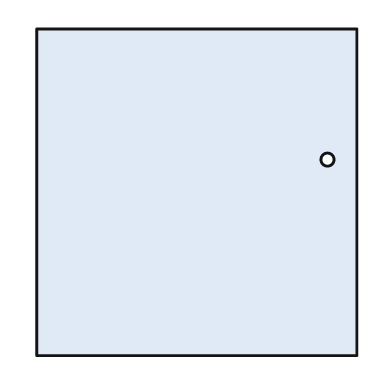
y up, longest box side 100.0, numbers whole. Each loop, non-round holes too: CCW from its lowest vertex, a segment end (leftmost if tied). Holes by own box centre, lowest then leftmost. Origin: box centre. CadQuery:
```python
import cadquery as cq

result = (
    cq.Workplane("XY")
    .moveTo(-49.0, -50.0)
    .lineTo(49.0, -50.0)
    .lineTo(49.0, 50.0)
    .lineTo(-49.0, 50.0)
    .close()
    .moveTo(40.0, 10.0)
    .circle(2.0)
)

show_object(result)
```